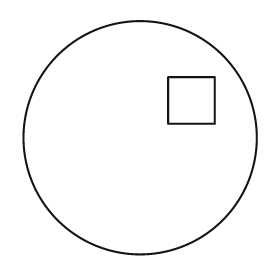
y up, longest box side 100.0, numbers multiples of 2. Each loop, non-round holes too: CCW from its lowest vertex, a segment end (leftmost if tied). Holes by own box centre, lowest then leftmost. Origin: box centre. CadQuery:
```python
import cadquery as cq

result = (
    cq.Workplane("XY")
    .moveTo(0.0, 0.0)
    .circle(50.0)
    .moveTo(12.0, 6.0)
    .lineTo(32.0, 6.0)
    .lineTo(32.0, 26.0)
    .lineTo(12.0, 26.0)
    .close()
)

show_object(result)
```